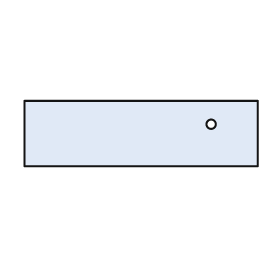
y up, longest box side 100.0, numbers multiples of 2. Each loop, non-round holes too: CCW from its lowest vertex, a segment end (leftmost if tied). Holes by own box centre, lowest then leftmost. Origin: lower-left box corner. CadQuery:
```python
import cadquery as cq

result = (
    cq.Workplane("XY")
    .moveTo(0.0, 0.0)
    .lineTo(100.0, 0.0)
    .lineTo(100.0, 28.0)
    .lineTo(0.0, 28.0)
    .close()
    .moveTo(80.0, 18.0)
    .circle(2.0)
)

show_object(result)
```